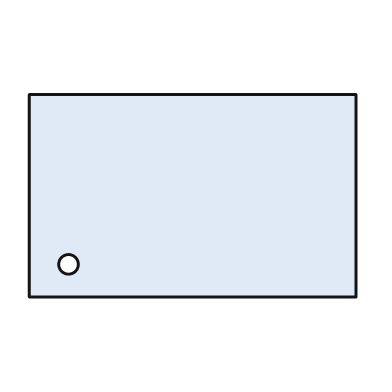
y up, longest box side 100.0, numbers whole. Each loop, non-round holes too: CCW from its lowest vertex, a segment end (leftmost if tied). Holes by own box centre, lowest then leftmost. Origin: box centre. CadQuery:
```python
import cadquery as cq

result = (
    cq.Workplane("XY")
    .moveTo(-50.0, -31.0)
    .lineTo(50.0, -31.0)
    .lineTo(50.0, 31.0)
    .lineTo(-50.0, 31.0)
    .close()
    .moveTo(-38.0, -21.0)
    .circle(3.0)
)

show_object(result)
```